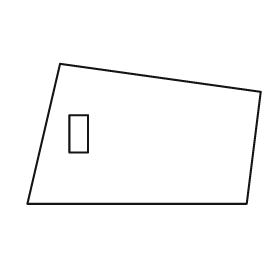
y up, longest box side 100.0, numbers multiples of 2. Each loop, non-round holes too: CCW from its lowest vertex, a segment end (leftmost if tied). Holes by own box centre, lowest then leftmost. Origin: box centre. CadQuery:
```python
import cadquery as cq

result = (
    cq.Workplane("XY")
    .moveTo(-50.0, -30.0)
    .lineTo(44.0, -30.0)
    .lineTo(50.0, 18.0)
    .lineTo(-36.0, 30.0)
    .close()
    .moveTo(-32.0, -8.0)
    .lineTo(-24.0, -8.0)
    .lineTo(-24.0, 8.0)
    .lineTo(-32.0, 8.0)
    .close()
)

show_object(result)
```